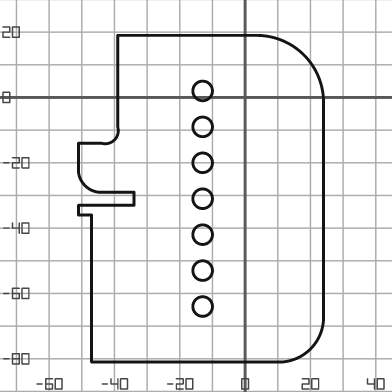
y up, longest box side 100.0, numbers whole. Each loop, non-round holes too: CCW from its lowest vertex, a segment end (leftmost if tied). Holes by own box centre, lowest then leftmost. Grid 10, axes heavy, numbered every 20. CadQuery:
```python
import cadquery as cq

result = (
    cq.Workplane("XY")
    .moveTo(-47.0, -81.0)
    .lineTo(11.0, -81.0)
    .threePointArc((20.0, -77.0), (24.0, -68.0))
    .lineTo(24.0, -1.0)
    .threePointArc((18.0, 13.0), (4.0, 19.0))
    .lineTo(-39.0, 19.0)
    .lineTo(-39.0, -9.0)
    .threePointArc((-40.0, -13.0), (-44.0, -14.0))
    .lineTo(-51.0, -14.0)
    .lineTo(-51.0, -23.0)
    .threePointArc((-49.0, -27.0), (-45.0, -29.0))
    .lineTo(-34.0, -29.0)
    .lineTo(-34.0, -33.0)
    .lineTo(-51.0, -33.0)
    .lineTo(-51.0, -36.0)
    .lineTo(-47.0, -36.0)
    .close()
    .moveTo(-13.0, -64.0)
    .circle(3.0)
    .moveTo(-13.0, -53.0)
    .circle(3.0)
    .moveTo(-13.0, -42.0)
    .circle(3.0)
    .moveTo(-13.0, -31.0)
    .circle(3.0)
    .moveTo(-13.0, -20.0)
    .circle(3.0)
    .moveTo(-13.0, -9.0)
    .circle(3.0)
    .moveTo(-13.0, 2.0)
    .circle(3.0)
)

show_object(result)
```